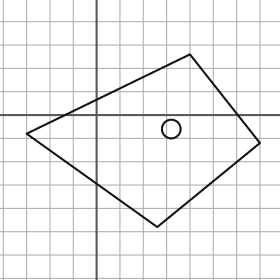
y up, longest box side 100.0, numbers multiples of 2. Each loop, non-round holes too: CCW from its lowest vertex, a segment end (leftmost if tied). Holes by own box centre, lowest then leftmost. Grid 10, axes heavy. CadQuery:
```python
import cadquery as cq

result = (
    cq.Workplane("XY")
    .moveTo(26.0, -48.0)
    .lineTo(70.0, -12.0)
    .lineTo(40.0, 26.0)
    .lineTo(-30.0, -8.0)
    .close()
    .moveTo(32.0, -6.0)
    .circle(4.0)
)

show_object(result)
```